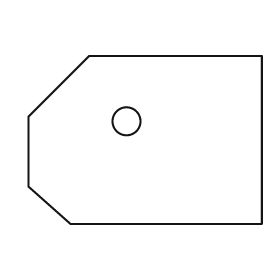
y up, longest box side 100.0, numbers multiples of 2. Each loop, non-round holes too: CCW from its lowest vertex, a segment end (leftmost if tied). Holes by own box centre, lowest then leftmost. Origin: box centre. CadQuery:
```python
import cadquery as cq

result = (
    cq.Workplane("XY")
    .moveTo(-32.0, -36.0)
    .lineTo(50.0, -36.0)
    .lineTo(50.0, 36.0)
    .lineTo(-24.0, 36.0)
    .lineTo(-50.0, 10.0)
    .lineTo(-50.0, -20.0)
    .close()
    .moveTo(-8.0, 8.0)
    .circle(6.0)
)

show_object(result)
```